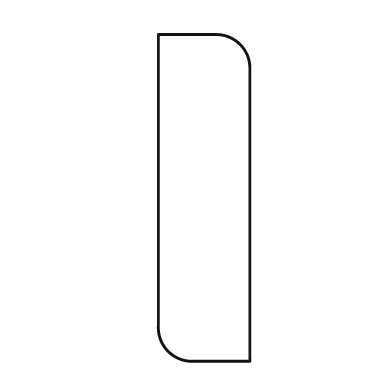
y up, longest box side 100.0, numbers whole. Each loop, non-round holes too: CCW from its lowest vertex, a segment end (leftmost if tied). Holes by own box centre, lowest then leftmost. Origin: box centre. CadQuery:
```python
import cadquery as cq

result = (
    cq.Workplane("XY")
    .moveTo(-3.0, -50.0)
    .lineTo(14.0, -50.0)
    .lineTo(14.0, 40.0)
    .threePointArc((11.0, 47.0), (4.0, 50.0))
    .lineTo(-14.0, 50.0)
    .lineTo(-14.0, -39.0)
    .threePointArc((-11.0, -47.0), (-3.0, -50.0))
    .close()
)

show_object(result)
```